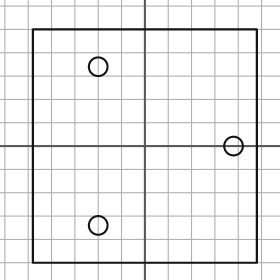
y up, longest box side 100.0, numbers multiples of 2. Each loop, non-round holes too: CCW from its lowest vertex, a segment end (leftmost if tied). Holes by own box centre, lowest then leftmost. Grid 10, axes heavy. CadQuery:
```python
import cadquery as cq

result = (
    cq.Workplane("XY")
    .moveTo(-48.0, -50.0)
    .lineTo(48.0, -50.0)
    .lineTo(48.0, 50.0)
    .lineTo(-48.0, 50.0)
    .close()
    .moveTo(-20.0, -34.0)
    .circle(4.0)
    .moveTo(38.0, 0.0)
    .circle(4.0)
    .moveTo(-20.0, 34.0)
    .circle(4.0)
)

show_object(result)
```